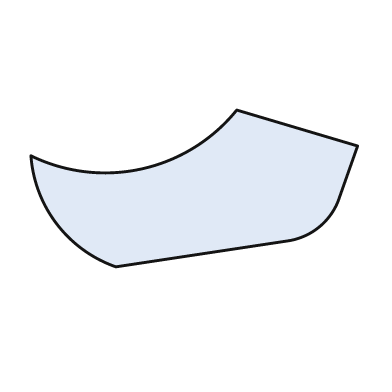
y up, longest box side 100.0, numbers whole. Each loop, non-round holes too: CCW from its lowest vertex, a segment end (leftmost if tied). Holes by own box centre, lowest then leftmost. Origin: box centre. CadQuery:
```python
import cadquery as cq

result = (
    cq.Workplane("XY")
    .moveTo(-24.0, -24.0)
    .lineTo(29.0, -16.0)
    .threePointArc((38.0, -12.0), (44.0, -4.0))
    .lineTo(50.0, 13.0)
    .lineTo(13.0, 24.0)
    .threePointArc((-16.0, 6.0), (-50.0, 10.0))
    .threePointArc((-42.0, -11.0), (-24.0, -24.0))
    .close()
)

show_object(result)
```